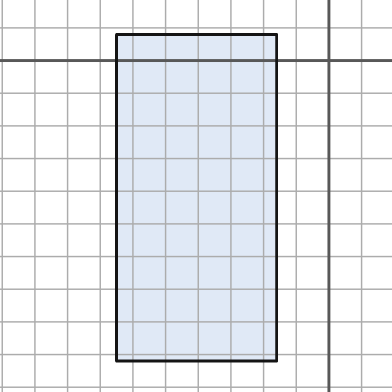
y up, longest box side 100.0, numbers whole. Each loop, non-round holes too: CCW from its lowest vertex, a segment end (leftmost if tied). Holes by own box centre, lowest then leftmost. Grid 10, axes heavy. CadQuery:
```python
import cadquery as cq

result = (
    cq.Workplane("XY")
    .moveTo(-65.0, -92.0)
    .lineTo(-16.0, -92.0)
    .lineTo(-16.0, 8.0)
    .lineTo(-65.0, 8.0)
    .close()
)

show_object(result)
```